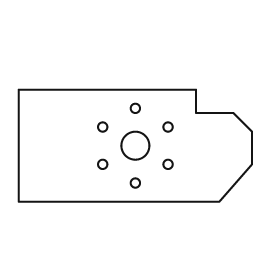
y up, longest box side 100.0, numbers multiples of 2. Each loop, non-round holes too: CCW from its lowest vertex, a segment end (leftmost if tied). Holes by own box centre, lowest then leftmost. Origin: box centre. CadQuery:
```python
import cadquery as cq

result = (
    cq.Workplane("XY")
    .moveTo(-50.0, -24.0)
    .lineTo(36.0, -24.0)
    .lineTo(50.0, -8.0)
    .lineTo(50.0, 6.0)
    .lineTo(42.0, 14.0)
    .lineTo(26.0, 14.0)
    .lineTo(26.0, 24.0)
    .lineTo(-50.0, 24.0)
    .close()
    .moveTo(0.0, -16.0)
    .circle(2.0)
    .moveTo(-14.0, -8.0)
    .circle(2.0)
    .moveTo(14.0, -8.0)
    .circle(2.0)
    .moveTo(0.0, 0.0)
    .circle(6.0)
    .moveTo(-14.0, 8.0)
    .circle(2.0)
    .moveTo(14.0, 8.0)
    .circle(2.0)
    .moveTo(0.0, 16.0)
    .circle(2.0)
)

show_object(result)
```